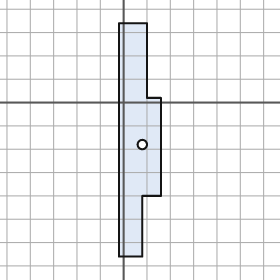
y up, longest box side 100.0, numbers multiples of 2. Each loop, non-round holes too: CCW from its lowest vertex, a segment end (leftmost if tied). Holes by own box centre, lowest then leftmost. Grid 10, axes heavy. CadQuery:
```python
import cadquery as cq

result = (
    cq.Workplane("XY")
    .moveTo(-2.0, -66.0)
    .lineTo(8.0, -66.0)
    .lineTo(8.0, -40.0)
    .lineTo(16.0, -40.0)
    .lineTo(16.0, 2.0)
    .lineTo(10.0, 2.0)
    .lineTo(10.0, 34.0)
    .lineTo(-2.0, 34.0)
    .close()
    .moveTo(8.0, -18.0)
    .circle(2.0)
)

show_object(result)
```